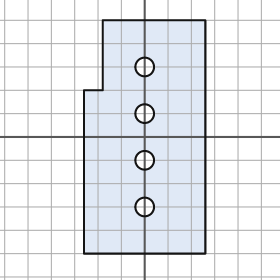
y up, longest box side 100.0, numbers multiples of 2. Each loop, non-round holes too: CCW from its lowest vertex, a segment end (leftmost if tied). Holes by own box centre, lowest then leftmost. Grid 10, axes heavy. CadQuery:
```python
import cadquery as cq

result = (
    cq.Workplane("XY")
    .moveTo(-26.0, -50.0)
    .lineTo(26.0, -50.0)
    .lineTo(26.0, 50.0)
    .lineTo(-18.0, 50.0)
    .lineTo(-18.0, 20.0)
    .lineTo(-26.0, 20.0)
    .close()
    .moveTo(0.0, -30.0)
    .circle(4.0)
    .moveTo(0.0, -10.0)
    .circle(4.0)
    .moveTo(0.0, 10.0)
    .circle(4.0)
    .moveTo(0.0, 30.0)
    .circle(4.0)
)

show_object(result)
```